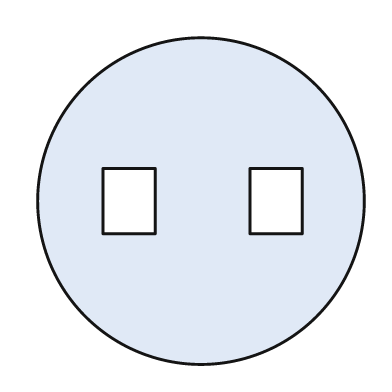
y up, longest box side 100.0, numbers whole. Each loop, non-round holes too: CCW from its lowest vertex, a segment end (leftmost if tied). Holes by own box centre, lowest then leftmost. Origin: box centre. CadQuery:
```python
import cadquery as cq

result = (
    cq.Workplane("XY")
    .moveTo(0.0, 0.0)
    .circle(50.0)
    .moveTo(-30.0, -10.0)
    .lineTo(-14.0, -10.0)
    .lineTo(-14.0, 10.0)
    .lineTo(-30.0, 10.0)
    .close()
    .moveTo(15.0, -10.0)
    .lineTo(31.0, -10.0)
    .lineTo(31.0, 10.0)
    .lineTo(15.0, 10.0)
    .close()
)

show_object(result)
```